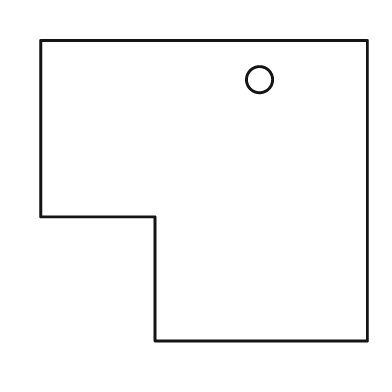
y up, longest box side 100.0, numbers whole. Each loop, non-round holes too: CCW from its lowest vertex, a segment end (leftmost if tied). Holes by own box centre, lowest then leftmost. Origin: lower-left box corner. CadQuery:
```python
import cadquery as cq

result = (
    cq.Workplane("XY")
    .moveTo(35.0, 0.0)
    .lineTo(100.0, 0.0)
    .lineTo(100.0, 92.0)
    .lineTo(0.0, 92.0)
    .lineTo(0.0, 38.0)
    .lineTo(35.0, 38.0)
    .close()
    .moveTo(67.0, 80.0)
    .circle(4.0)
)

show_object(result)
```